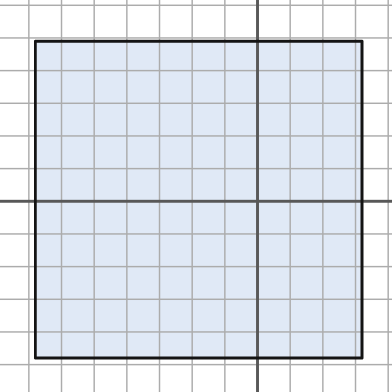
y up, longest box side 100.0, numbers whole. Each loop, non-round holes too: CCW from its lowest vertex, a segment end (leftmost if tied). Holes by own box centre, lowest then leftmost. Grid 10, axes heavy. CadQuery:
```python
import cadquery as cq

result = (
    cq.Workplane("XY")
    .moveTo(-68.0, -48.0)
    .lineTo(32.0, -48.0)
    .lineTo(32.0, 49.0)
    .lineTo(-68.0, 49.0)
    .close()
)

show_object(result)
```